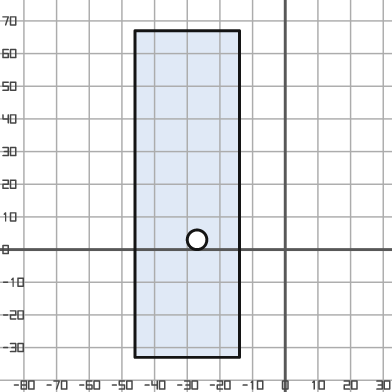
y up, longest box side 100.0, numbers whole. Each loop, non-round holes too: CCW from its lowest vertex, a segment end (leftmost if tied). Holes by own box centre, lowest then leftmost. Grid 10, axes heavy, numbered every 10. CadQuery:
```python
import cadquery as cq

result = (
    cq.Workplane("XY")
    .moveTo(-46.0, -33.0)
    .lineTo(-14.0, -33.0)
    .lineTo(-14.0, 67.0)
    .lineTo(-46.0, 67.0)
    .close()
    .moveTo(-27.0, 3.0)
    .circle(3.0)
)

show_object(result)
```